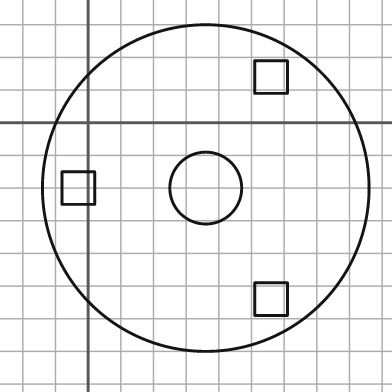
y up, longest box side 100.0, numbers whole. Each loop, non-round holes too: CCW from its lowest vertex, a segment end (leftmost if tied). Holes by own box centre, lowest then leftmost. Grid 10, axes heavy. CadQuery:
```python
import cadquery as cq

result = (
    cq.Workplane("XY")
    .moveTo(36.0, -20.0)
    .circle(50.0)
    .moveTo(51.0, -59.0)
    .lineTo(61.0, -59.0)
    .lineTo(61.0, -49.0)
    .lineTo(51.0, -49.0)
    .close()
    .moveTo(-8.0, -25.0)
    .lineTo(2.0, -25.0)
    .lineTo(2.0, -15.0)
    .lineTo(-8.0, -15.0)
    .close()
    .moveTo(36.0, -20.0)
    .circle(11.0)
    .moveTo(51.0, 9.0)
    .lineTo(61.0, 9.0)
    .lineTo(61.0, 19.0)
    .lineTo(51.0, 19.0)
    .close()
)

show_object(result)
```